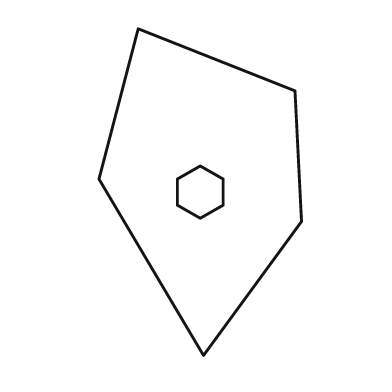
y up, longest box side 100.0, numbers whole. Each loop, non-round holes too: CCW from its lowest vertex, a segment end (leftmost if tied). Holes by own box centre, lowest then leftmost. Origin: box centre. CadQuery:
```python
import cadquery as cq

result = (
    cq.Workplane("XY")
    .moveTo(1.0, -50.0)
    .lineTo(31.0, -9.0)
    .lineTo(29.0, 31.0)
    .lineTo(-19.0, 50.0)
    .lineTo(-31.0, 4.0)
    .close()
    .moveTo(0.0, -8.0)
    .lineTo(7.0, -4.0)
    .lineTo(7.0, 4.0)
    .lineTo(0.0, 8.0)
    .lineTo(-7.0, 4.0)
    .lineTo(-7.0, -4.0)
    .close()
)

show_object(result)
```